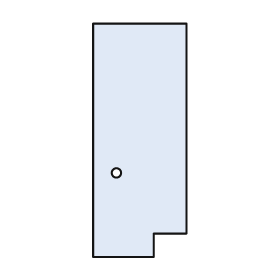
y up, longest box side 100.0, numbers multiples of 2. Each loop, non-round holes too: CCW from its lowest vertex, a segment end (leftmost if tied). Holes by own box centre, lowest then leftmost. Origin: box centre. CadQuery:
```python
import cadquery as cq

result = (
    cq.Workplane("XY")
    .moveTo(-20.0, -50.0)
    .lineTo(6.0, -50.0)
    .lineTo(6.0, -40.0)
    .lineTo(20.0, -40.0)
    .lineTo(20.0, 50.0)
    .lineTo(-20.0, 50.0)
    .close()
    .moveTo(-10.0, -14.0)
    .circle(2.0)
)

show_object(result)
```